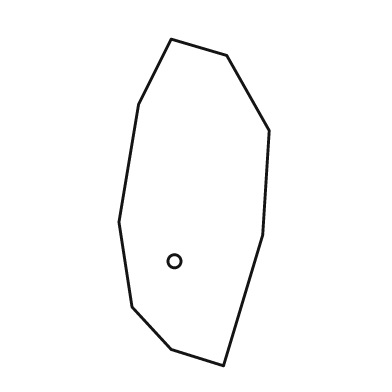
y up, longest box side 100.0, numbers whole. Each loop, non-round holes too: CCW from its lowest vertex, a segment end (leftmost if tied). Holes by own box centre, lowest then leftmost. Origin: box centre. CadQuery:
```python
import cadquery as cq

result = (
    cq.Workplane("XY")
    .moveTo(9.0, -50.0)
    .lineTo(21.0, -10.0)
    .lineTo(23.0, 22.0)
    .lineTo(10.0, 45.0)
    .lineTo(-7.0, 50.0)
    .lineTo(-17.0, 30.0)
    .lineTo(-23.0, -6.0)
    .lineTo(-19.0, -32.0)
    .lineTo(-7.0, -45.0)
    .close()
    .moveTo(-6.0, -18.0)
    .circle(2.0)
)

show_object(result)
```